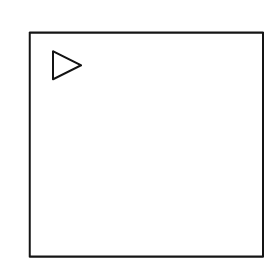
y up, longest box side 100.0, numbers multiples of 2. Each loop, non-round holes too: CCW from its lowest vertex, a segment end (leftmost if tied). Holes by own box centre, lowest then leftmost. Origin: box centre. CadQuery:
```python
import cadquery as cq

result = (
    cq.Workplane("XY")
    .moveTo(-50.0, -48.0)
    .lineTo(50.0, -48.0)
    .lineTo(50.0, 48.0)
    .lineTo(-50.0, 48.0)
    .close()
    .moveTo(-40.0, 28.0)
    .lineTo(-28.0, 34.0)
    .lineTo(-40.0, 40.0)
    .close()
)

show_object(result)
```